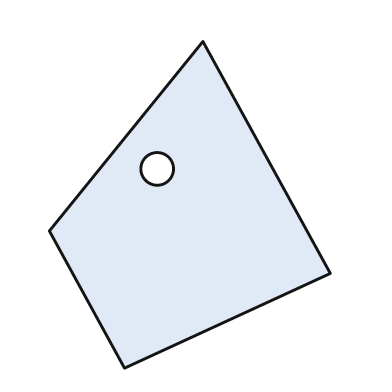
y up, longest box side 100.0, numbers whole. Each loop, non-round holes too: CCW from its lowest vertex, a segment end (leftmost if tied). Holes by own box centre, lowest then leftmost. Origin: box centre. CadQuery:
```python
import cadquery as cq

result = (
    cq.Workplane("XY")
    .moveTo(-20.0, -50.0)
    .lineTo(43.0, -21.0)
    .lineTo(4.0, 50.0)
    .lineTo(-43.0, -8.0)
    .close()
    .moveTo(-10.0, 11.0)
    .circle(5.0)
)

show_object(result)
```